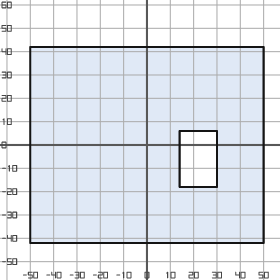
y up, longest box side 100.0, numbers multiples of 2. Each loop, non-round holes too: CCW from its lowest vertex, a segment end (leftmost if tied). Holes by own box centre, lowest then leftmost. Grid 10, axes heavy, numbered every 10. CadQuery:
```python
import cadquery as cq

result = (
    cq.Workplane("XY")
    .moveTo(-50.0, -42.0)
    .lineTo(50.0, -42.0)
    .lineTo(50.0, 42.0)
    .lineTo(-50.0, 42.0)
    .close()
    .moveTo(14.0, -18.0)
    .lineTo(30.0, -18.0)
    .lineTo(30.0, 6.0)
    .lineTo(14.0, 6.0)
    .close()
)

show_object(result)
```